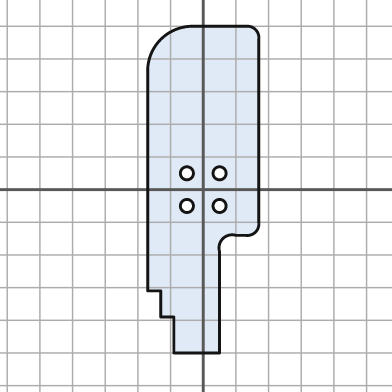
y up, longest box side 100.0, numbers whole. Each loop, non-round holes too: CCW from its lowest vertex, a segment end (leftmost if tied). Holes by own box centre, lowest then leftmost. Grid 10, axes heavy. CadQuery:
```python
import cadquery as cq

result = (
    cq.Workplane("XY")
    .moveTo(-9.0, -50.0)
    .lineTo(5.0, -50.0)
    .lineTo(5.0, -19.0)
    .threePointArc((6.0, -15.0), (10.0, -14.0))
    .lineTo(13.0, -14.0)
    .threePointArc((16.0, -13.0), (17.0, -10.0))
    .lineTo(17.0, 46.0)
    .threePointArc((16.0, 49.0), (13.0, 50.0))
    .lineTo(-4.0, 50.0)
    .threePointArc((-13.0, 46.0), (-17.0, 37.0))
    .lineTo(-17.0, -31.0)
    .lineTo(-13.0, -31.0)
    .lineTo(-13.0, -39.0)
    .lineTo(-9.0, -39.0)
    .close()
    .moveTo(-5.0, -5.0)
    .circle(2.0)
    .moveTo(5.0, -5.0)
    .circle(2.0)
    .moveTo(-5.0, 5.0)
    .circle(2.0)
    .moveTo(5.0, 5.0)
    .circle(2.0)
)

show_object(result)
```